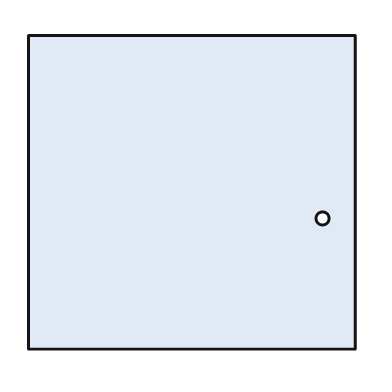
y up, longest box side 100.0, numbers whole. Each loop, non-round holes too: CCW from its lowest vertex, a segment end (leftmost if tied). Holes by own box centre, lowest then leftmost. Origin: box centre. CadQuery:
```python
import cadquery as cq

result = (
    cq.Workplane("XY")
    .moveTo(-50.0, -48.0)
    .lineTo(50.0, -48.0)
    .lineTo(50.0, 48.0)
    .lineTo(-50.0, 48.0)
    .close()
    .moveTo(40.0, -8.0)
    .circle(2.0)
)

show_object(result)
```